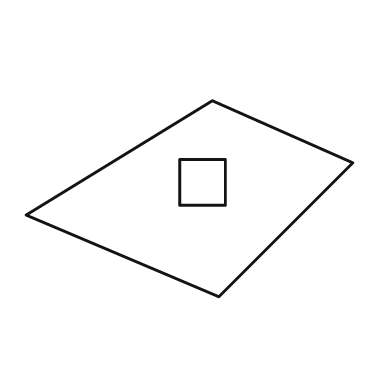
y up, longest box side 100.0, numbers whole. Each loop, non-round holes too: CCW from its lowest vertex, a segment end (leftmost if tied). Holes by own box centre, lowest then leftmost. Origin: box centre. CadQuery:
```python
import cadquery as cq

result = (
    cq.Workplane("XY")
    .moveTo(9.0, -30.0)
    .lineTo(50.0, 11.0)
    .lineTo(7.0, 30.0)
    .lineTo(-50.0, -5.0)
    .close()
    .moveTo(-3.0, -2.0)
    .lineTo(11.0, -2.0)
    .lineTo(11.0, 12.0)
    .lineTo(-3.0, 12.0)
    .close()
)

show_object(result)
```